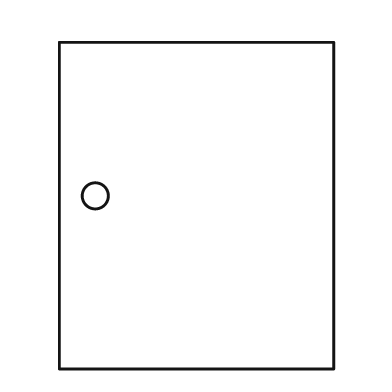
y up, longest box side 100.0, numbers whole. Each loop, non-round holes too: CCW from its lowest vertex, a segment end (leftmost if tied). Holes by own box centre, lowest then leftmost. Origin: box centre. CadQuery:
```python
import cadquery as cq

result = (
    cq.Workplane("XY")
    .moveTo(-42.0, -50.0)
    .lineTo(42.0, -50.0)
    .lineTo(42.0, 50.0)
    .lineTo(-42.0, 50.0)
    .close()
    .moveTo(-31.0, 3.0)
    .circle(4.0)
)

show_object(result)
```